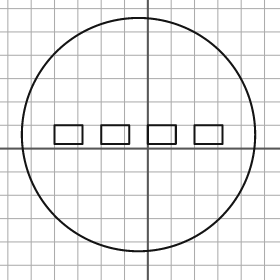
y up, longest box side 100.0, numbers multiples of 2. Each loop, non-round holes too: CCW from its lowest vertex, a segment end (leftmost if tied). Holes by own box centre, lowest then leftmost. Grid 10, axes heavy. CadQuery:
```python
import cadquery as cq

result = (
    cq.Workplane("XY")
    .moveTo(-4.0, 6.0)
    .circle(50.0)
    .moveTo(-40.0, 2.0)
    .lineTo(-28.0, 2.0)
    .lineTo(-28.0, 10.0)
    .lineTo(-40.0, 10.0)
    .close()
    .moveTo(-20.0, 2.0)
    .lineTo(-8.0, 2.0)
    .lineTo(-8.0, 10.0)
    .lineTo(-20.0, 10.0)
    .close()
    .moveTo(0.0, 2.0)
    .lineTo(12.0, 2.0)
    .lineTo(12.0, 10.0)
    .lineTo(0.0, 10.0)
    .close()
    .moveTo(20.0, 2.0)
    .lineTo(32.0, 2.0)
    .lineTo(32.0, 10.0)
    .lineTo(20.0, 10.0)
    .close()
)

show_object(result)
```